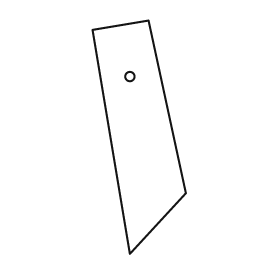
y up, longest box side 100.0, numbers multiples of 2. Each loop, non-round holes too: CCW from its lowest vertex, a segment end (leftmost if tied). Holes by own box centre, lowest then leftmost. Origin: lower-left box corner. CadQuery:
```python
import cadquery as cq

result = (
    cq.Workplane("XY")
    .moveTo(16.0, 0.0)
    .lineTo(40.0, 26.0)
    .lineTo(24.0, 100.0)
    .lineTo(0.0, 96.0)
    .close()
    .moveTo(16.0, 76.0)
    .circle(2.0)
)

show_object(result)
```